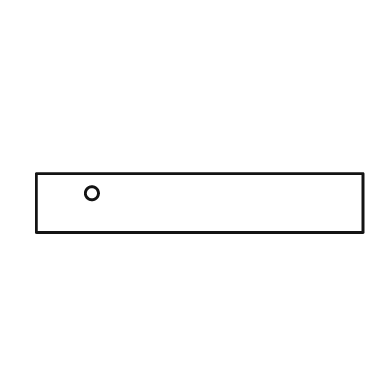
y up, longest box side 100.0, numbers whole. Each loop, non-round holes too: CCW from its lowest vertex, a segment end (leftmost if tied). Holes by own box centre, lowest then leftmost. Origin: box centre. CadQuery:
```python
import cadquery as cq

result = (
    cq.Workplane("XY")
    .moveTo(-50.0, -9.0)
    .lineTo(50.0, -9.0)
    .lineTo(50.0, 9.0)
    .lineTo(-50.0, 9.0)
    .close()
    .moveTo(-33.0, 3.0)
    .circle(2.0)
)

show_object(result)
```